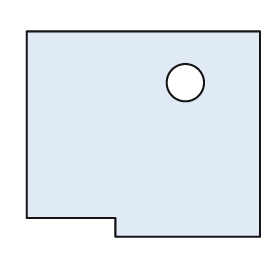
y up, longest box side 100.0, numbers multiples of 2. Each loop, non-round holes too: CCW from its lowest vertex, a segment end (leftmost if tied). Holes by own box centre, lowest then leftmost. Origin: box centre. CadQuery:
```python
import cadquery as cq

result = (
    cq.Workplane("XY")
    .moveTo(-12.0, -44.0)
    .lineTo(50.0, -44.0)
    .lineTo(50.0, 44.0)
    .lineTo(-50.0, 44.0)
    .lineTo(-50.0, -36.0)
    .lineTo(-12.0, -36.0)
    .close()
    .moveTo(18.0, 22.0)
    .circle(8.0)
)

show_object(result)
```